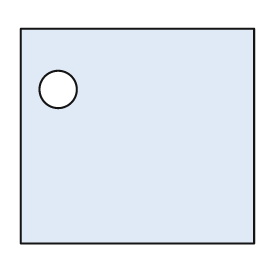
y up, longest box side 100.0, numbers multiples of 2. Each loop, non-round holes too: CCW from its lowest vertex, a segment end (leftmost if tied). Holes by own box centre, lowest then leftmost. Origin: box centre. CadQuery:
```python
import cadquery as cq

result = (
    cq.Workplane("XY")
    .moveTo(-50.0, -46.0)
    .lineTo(50.0, -46.0)
    .lineTo(50.0, 46.0)
    .lineTo(-50.0, 46.0)
    .close()
    .moveTo(-34.0, 20.0)
    .circle(8.0)
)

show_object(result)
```